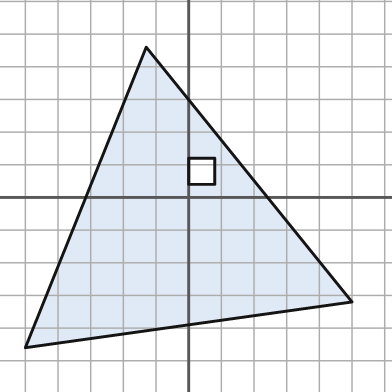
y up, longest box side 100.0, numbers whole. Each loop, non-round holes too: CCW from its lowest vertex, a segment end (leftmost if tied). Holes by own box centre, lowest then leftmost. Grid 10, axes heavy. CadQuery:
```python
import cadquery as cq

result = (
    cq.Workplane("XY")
    .moveTo(-50.0, -46.0)
    .lineTo(50.0, -32.0)
    .lineTo(-13.0, 46.0)
    .close()
    .moveTo(0.0, 4.0)
    .lineTo(8.0, 4.0)
    .lineTo(8.0, 12.0)
    .lineTo(0.0, 12.0)
    .close()
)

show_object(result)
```